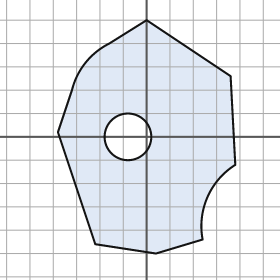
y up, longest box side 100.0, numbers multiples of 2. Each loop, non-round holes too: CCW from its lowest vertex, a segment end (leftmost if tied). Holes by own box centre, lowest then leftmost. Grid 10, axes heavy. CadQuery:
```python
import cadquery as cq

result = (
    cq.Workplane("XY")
    .moveTo(4.0, -50.0)
    .lineTo(24.0, -44.0)
    .threePointArc((26.0, -26.0), (38.0, -12.0))
    .lineTo(36.0, 26.0)
    .lineTo(0.0, 50.0)
    .lineTo(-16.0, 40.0)
    .threePointArc((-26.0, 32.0), (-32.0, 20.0))
    .lineTo(-38.0, 2.0)
    .lineTo(-22.0, -46.0)
    .close()
    .moveTo(-8.0, 0.0)
    .circle(10.0)
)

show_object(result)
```